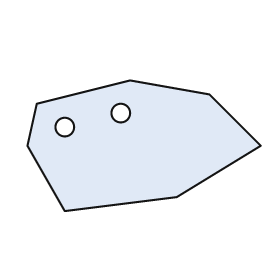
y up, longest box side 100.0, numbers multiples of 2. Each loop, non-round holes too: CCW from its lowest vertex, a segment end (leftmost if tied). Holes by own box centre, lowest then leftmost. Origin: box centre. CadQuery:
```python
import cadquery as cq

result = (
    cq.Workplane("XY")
    .moveTo(-34.0, -28.0)
    .lineTo(14.0, -22.0)
    .lineTo(50.0, 0.0)
    .lineTo(28.0, 22.0)
    .lineTo(-6.0, 28.0)
    .lineTo(-46.0, 18.0)
    .lineTo(-50.0, 0.0)
    .close()
    .moveTo(-34.0, 8.0)
    .circle(4.0)
    .moveTo(-10.0, 14.0)
    .circle(4.0)
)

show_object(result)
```